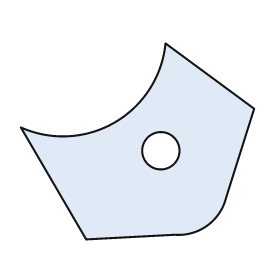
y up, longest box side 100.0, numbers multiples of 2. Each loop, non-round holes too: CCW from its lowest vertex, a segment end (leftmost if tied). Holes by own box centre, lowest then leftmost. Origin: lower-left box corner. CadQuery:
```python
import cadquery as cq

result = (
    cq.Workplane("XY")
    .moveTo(28.0, 0.0)
    .lineTo(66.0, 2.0)
    .threePointArc((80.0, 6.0), (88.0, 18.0))
    .lineTo(100.0, 56.0)
    .lineTo(62.0, 84.0)
    .threePointArc((40.0, 50.0), (0.0, 48.0))
    .close()
    .moveTo(60.0, 38.0)
    .circle(8.0)
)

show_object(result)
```